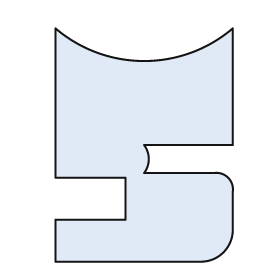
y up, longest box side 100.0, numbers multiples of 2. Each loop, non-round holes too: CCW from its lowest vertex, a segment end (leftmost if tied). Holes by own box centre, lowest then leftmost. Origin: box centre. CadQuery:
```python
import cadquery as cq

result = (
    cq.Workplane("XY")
    .moveTo(-38.0, -50.0)
    .lineTo(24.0, -50.0)
    .threePointArc((34.0, -46.0), (38.0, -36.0))
    .lineTo(38.0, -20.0)
    .threePointArc((36.0, -14.0), (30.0, -12.0))
    .lineTo(0.0, -12.0)
    .threePointArc((2.0, -6.0), (0.0, 0.0))
    .lineTo(38.0, 0.0)
    .lineTo(38.0, 50.0)
    .threePointArc((0.0, 36.0), (-38.0, 50.0))
    .lineTo(-38.0, -14.0)
    .lineTo(-8.0, -14.0)
    .lineTo(-8.0, -32.0)
    .lineTo(-38.0, -32.0)
    .close()
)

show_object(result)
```